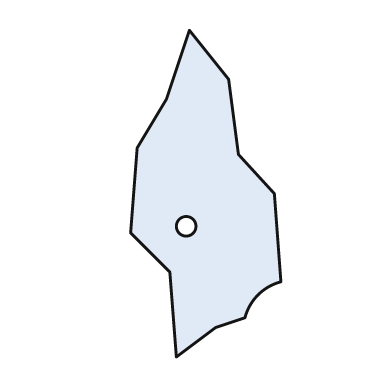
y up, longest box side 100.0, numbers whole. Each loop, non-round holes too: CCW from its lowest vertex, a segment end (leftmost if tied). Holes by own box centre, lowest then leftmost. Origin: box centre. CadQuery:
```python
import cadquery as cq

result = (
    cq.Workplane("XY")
    .moveTo(-9.0, -50.0)
    .lineTo(3.0, -41.0)
    .lineTo(12.0, -38.0)
    .threePointArc((16.0, -31.0), (23.0, -27.0))
    .lineTo(21.0, 0.0)
    .lineTo(10.0, 12.0)
    .lineTo(7.0, 35.0)
    .lineTo(-5.0, 50.0)
    .lineTo(-12.0, 29.0)
    .lineTo(-21.0, 14.0)
    .lineTo(-23.0, -12.0)
    .lineTo(-11.0, -24.0)
    .close()
    .moveTo(-6.0, -10.0)
    .circle(3.0)
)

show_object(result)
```